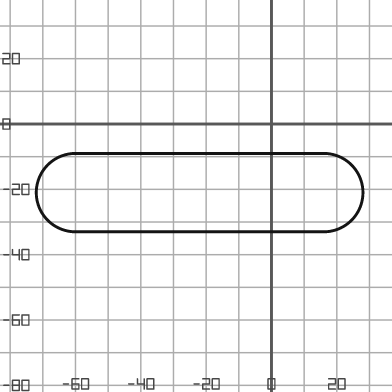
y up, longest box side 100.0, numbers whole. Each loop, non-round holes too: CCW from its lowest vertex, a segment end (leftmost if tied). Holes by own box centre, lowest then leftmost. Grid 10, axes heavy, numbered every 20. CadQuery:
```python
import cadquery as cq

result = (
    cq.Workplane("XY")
    .moveTo(-60.0, -33.0)
    .lineTo(16.0, -33.0)
    .threePointArc((28.0, -21.0), (16.0, -9.0))
    .lineTo(-60.0, -9.0)
    .threePointArc((-72.0, -21.0), (-60.0, -33.0))
    .close()
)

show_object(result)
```